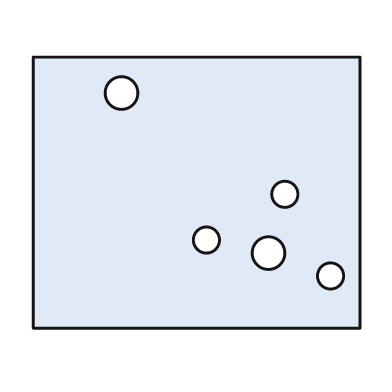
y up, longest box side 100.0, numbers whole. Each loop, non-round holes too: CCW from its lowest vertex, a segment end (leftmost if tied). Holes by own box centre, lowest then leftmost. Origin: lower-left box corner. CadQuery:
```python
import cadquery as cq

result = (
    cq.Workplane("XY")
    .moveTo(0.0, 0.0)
    .lineTo(100.0, 0.0)
    .lineTo(100.0, 83.0)
    .lineTo(0.0, 83.0)
    .close()
    .moveTo(91.0, 16.0)
    .circle(4.0)
    .moveTo(72.0, 23.0)
    .circle(5.0)
    .moveTo(53.0, 27.0)
    .circle(4.0)
    .moveTo(77.0, 41.0)
    .circle(4.0)
    .moveTo(27.0, 72.0)
    .circle(5.0)
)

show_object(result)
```